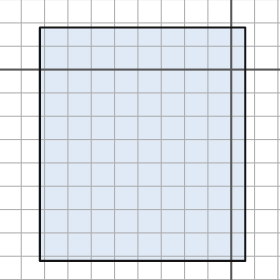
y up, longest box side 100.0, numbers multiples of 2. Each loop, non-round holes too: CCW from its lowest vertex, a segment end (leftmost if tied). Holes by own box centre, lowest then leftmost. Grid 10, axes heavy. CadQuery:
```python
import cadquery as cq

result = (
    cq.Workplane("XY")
    .moveTo(-82.0, -82.0)
    .lineTo(6.0, -82.0)
    .lineTo(6.0, 18.0)
    .lineTo(-82.0, 18.0)
    .close()
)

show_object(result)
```